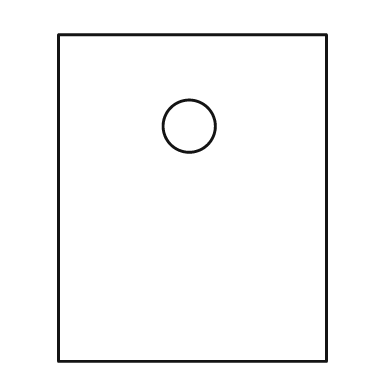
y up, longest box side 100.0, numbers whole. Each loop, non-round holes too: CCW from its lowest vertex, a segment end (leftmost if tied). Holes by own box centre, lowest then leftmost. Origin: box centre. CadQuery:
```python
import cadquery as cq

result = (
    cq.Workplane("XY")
    .moveTo(-41.0, -50.0)
    .lineTo(41.0, -50.0)
    .lineTo(41.0, 50.0)
    .lineTo(-41.0, 50.0)
    .close()
    .moveTo(-1.0, 22.0)
    .circle(8.0)
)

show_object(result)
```